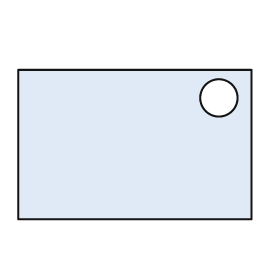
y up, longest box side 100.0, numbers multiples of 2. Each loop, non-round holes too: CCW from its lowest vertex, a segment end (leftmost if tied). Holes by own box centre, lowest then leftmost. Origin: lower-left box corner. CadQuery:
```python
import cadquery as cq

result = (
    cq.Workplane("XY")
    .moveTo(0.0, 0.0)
    .lineTo(100.0, 0.0)
    .lineTo(100.0, 64.0)
    .lineTo(0.0, 64.0)
    .close()
    .moveTo(86.0, 52.0)
    .circle(8.0)
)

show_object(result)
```